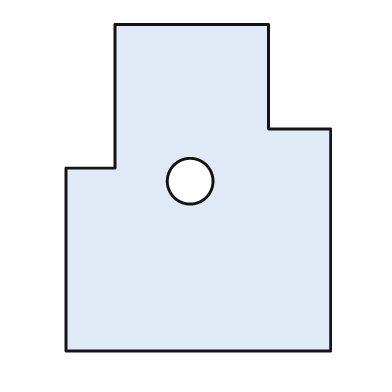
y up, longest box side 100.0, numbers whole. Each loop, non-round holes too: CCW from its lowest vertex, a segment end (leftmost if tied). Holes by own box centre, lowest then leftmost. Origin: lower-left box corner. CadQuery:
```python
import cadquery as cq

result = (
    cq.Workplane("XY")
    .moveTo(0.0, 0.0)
    .lineTo(81.0, 0.0)
    .lineTo(81.0, 68.0)
    .lineTo(62.0, 68.0)
    .lineTo(62.0, 100.0)
    .lineTo(15.0, 100.0)
    .lineTo(15.0, 56.0)
    .lineTo(0.0, 56.0)
    .close()
    .moveTo(38.0, 52.0)
    .circle(7.0)
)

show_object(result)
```